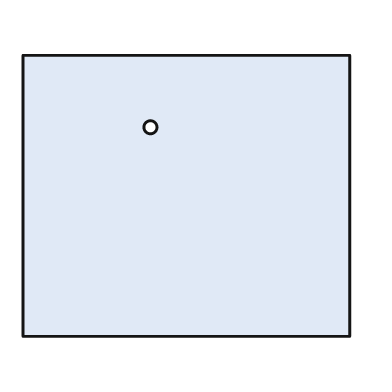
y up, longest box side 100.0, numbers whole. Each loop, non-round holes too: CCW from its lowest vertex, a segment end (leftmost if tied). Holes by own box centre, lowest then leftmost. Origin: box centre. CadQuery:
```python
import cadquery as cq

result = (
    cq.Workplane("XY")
    .moveTo(-50.0, -43.0)
    .lineTo(50.0, -43.0)
    .lineTo(50.0, 43.0)
    .lineTo(-50.0, 43.0)
    .close()
    .moveTo(-11.0, 21.0)
    .circle(2.0)
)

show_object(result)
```